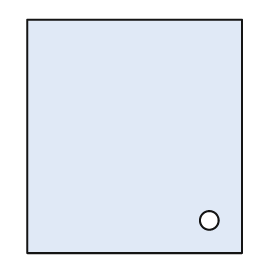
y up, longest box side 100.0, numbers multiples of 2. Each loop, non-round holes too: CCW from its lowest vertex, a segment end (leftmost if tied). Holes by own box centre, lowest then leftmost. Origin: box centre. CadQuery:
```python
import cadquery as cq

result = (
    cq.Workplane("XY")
    .moveTo(-46.0, -50.0)
    .lineTo(46.0, -50.0)
    .lineTo(46.0, 50.0)
    .lineTo(-46.0, 50.0)
    .close()
    .moveTo(32.0, -36.0)
    .circle(4.0)
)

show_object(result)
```